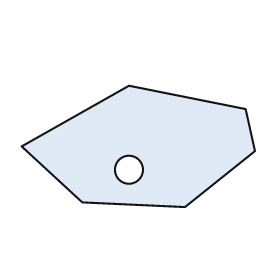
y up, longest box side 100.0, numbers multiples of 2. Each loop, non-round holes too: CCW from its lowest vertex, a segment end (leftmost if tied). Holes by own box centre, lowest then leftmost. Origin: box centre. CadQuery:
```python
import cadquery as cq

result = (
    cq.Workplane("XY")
    .moveTo(20.0, -26.0)
    .lineTo(50.0, -2.0)
    .lineTo(46.0, 16.0)
    .lineTo(-4.0, 26.0)
    .lineTo(-50.0, 0.0)
    .lineTo(-24.0, -24.0)
    .close()
    .moveTo(-4.0, -10.0)
    .circle(6.0)
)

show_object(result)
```